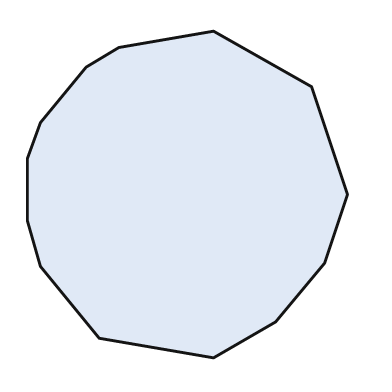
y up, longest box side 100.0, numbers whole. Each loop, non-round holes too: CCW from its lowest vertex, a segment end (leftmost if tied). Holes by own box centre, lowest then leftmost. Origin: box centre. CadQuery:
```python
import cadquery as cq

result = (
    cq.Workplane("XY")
    .moveTo(8.0, -50.0)
    .lineTo(27.0, -39.0)
    .lineTo(42.0, -21.0)
    .lineTo(49.0, 0.0)
    .lineTo(38.0, 33.0)
    .lineTo(8.0, 50.0)
    .lineTo(-21.0, 45.0)
    .lineTo(-31.0, 39.0)
    .lineTo(-45.0, 22.0)
    .lineTo(-49.0, 11.0)
    .lineTo(-49.0, -8.0)
    .lineTo(-45.0, -22.0)
    .lineTo(-27.0, -44.0)
    .close()
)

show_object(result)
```